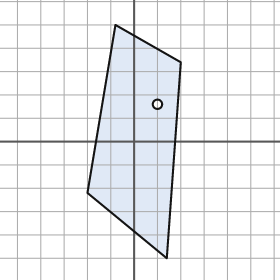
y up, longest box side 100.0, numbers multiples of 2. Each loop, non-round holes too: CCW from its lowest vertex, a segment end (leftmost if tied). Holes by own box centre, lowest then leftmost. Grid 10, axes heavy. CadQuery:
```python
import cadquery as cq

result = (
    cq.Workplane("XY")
    .moveTo(14.0, -50.0)
    .lineTo(20.0, 34.0)
    .lineTo(-8.0, 50.0)
    .lineTo(-20.0, -22.0)
    .close()
    .moveTo(10.0, 16.0)
    .circle(2.0)
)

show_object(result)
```